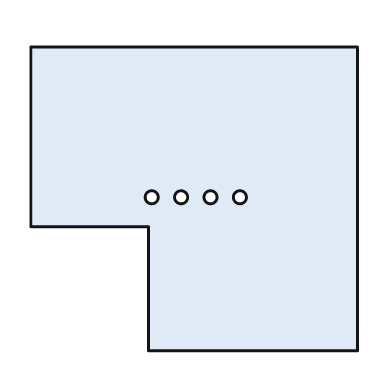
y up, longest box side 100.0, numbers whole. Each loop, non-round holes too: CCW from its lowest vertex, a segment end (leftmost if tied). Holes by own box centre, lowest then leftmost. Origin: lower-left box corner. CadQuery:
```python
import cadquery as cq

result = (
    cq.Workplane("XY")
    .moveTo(36.0, 0.0)
    .lineTo(100.0, 0.0)
    .lineTo(100.0, 93.0)
    .lineTo(0.0, 93.0)
    .lineTo(0.0, 38.0)
    .lineTo(36.0, 38.0)
    .close()
    .moveTo(37.0, 47.0)
    .circle(2.0)
    .moveTo(46.0, 47.0)
    .circle(2.0)
    .moveTo(55.0, 47.0)
    .circle(2.0)
    .moveTo(64.0, 47.0)
    .circle(2.0)
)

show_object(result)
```